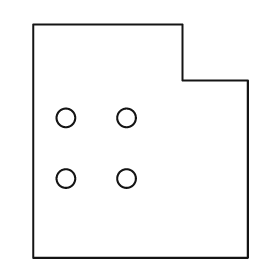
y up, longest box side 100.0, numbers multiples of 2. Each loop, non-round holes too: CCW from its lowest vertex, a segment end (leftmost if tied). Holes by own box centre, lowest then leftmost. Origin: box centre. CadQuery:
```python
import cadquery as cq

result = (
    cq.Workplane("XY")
    .moveTo(-46.0, -50.0)
    .lineTo(46.0, -50.0)
    .lineTo(46.0, 26.0)
    .lineTo(18.0, 26.0)
    .lineTo(18.0, 50.0)
    .lineTo(-46.0, 50.0)
    .close()
    .moveTo(-32.0, -16.0)
    .circle(4.0)
    .moveTo(-6.0, -16.0)
    .circle(4.0)
    .moveTo(-32.0, 10.0)
    .circle(4.0)
    .moveTo(-6.0, 10.0)
    .circle(4.0)
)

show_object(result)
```